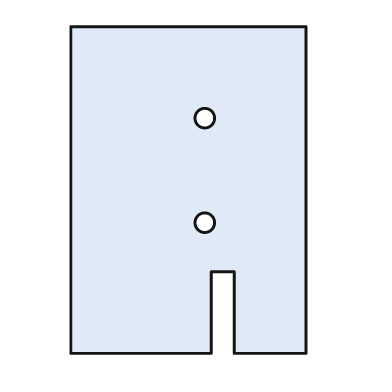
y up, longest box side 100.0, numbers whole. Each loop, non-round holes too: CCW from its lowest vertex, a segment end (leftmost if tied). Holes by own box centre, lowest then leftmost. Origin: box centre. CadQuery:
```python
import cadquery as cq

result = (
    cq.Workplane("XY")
    .moveTo(-36.0, -50.0)
    .lineTo(7.0, -50.0)
    .lineTo(7.0, -25.0)
    .lineTo(14.0, -25.0)
    .lineTo(14.0, -50.0)
    .lineTo(36.0, -50.0)
    .lineTo(36.0, 50.0)
    .lineTo(-36.0, 50.0)
    .close()
    .moveTo(5.0, -10.0)
    .circle(3.0)
    .moveTo(5.0, 22.0)
    .circle(3.0)
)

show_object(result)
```